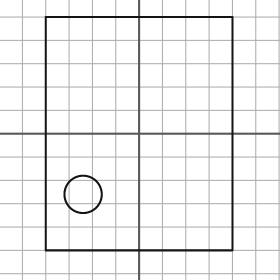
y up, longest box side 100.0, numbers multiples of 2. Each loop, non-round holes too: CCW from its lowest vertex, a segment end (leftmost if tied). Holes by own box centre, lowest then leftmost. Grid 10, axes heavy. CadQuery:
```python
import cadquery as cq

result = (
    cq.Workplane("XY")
    .moveTo(-40.0, -50.0)
    .lineTo(40.0, -50.0)
    .lineTo(40.0, 50.0)
    .lineTo(-40.0, 50.0)
    .close()
    .moveTo(-24.0, -26.0)
    .circle(8.0)
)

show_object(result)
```